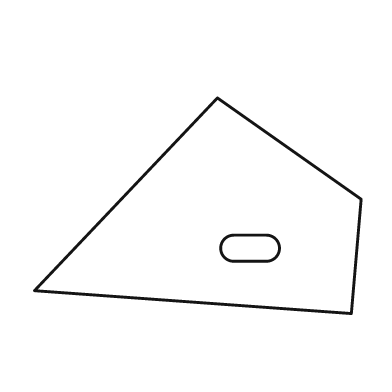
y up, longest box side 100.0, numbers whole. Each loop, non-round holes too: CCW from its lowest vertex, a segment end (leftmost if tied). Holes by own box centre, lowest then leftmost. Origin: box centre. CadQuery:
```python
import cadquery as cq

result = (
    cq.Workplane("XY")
    .moveTo(47.0, -33.0)
    .lineTo(50.0, 2.0)
    .lineTo(6.0, 33.0)
    .lineTo(-50.0, -26.0)
    .close()
    .moveTo(11.0, -17.0)
    .lineTo(21.0, -17.0)
    .threePointArc((25.0, -13.0), (21.0, -9.0))
    .lineTo(11.0, -9.0)
    .threePointArc((7.0, -13.0), (11.0, -17.0))
    .close()
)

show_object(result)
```